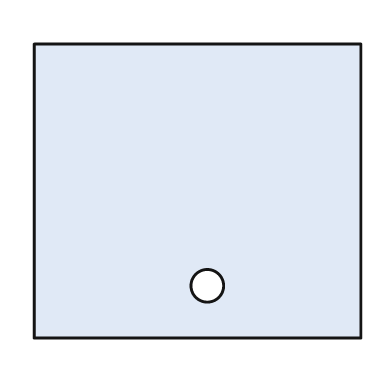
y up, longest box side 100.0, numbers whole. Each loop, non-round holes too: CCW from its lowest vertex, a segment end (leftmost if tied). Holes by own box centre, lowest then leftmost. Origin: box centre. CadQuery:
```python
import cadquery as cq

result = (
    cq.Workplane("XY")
    .moveTo(-50.0, -45.0)
    .lineTo(50.0, -45.0)
    .lineTo(50.0, 45.0)
    .lineTo(-50.0, 45.0)
    .close()
    .moveTo(3.0, -29.0)
    .circle(5.0)
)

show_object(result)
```